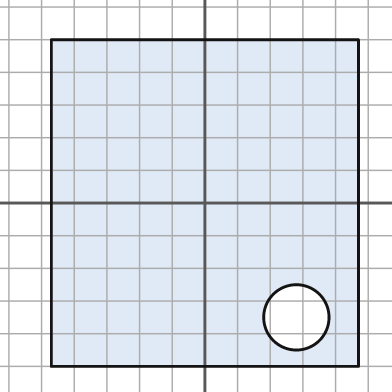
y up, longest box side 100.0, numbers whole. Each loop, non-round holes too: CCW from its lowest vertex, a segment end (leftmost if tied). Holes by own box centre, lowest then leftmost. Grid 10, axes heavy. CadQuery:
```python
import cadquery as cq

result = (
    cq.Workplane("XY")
    .moveTo(-47.0, -50.0)
    .lineTo(47.0, -50.0)
    .lineTo(47.0, 50.0)
    .lineTo(-47.0, 50.0)
    .close()
    .moveTo(28.0, -35.0)
    .circle(10.0)
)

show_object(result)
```